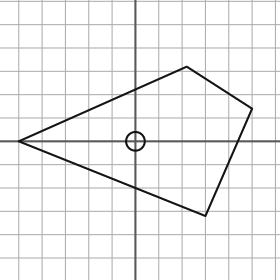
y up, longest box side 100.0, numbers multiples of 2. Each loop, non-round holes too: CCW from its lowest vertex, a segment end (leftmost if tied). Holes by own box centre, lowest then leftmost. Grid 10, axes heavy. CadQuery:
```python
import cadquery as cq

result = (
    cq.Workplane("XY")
    .moveTo(30.0, -32.0)
    .lineTo(50.0, 14.0)
    .lineTo(22.0, 32.0)
    .lineTo(-50.0, 0.0)
    .close()
    .moveTo(0.0, 0.0)
    .circle(4.0)
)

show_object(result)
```